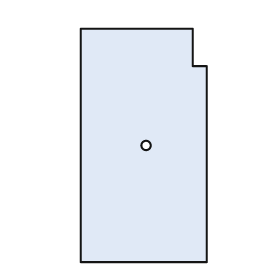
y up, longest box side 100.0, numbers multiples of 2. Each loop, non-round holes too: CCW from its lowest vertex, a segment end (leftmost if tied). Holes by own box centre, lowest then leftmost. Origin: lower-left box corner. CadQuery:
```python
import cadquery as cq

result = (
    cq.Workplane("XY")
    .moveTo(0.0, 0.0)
    .lineTo(54.0, 0.0)
    .lineTo(54.0, 84.0)
    .lineTo(48.0, 84.0)
    .lineTo(48.0, 100.0)
    .lineTo(0.0, 100.0)
    .close()
    .moveTo(28.0, 50.0)
    .circle(2.0)
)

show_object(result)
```